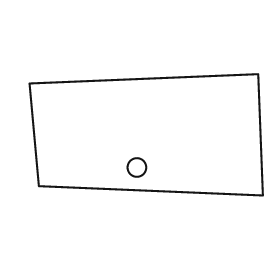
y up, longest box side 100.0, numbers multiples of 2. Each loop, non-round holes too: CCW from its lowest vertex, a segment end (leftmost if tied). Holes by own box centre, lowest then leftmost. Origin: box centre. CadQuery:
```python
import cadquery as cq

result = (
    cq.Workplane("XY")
    .moveTo(50.0, -26.0)
    .lineTo(48.0, 26.0)
    .lineTo(-50.0, 22.0)
    .lineTo(-46.0, -22.0)
    .close()
    .moveTo(-4.0, -14.0)
    .circle(4.0)
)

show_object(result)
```